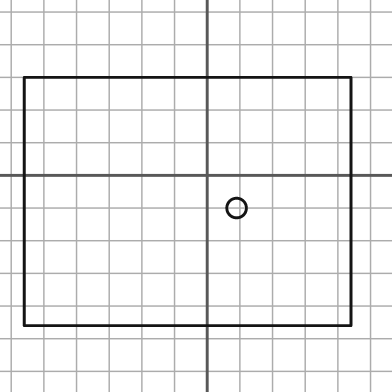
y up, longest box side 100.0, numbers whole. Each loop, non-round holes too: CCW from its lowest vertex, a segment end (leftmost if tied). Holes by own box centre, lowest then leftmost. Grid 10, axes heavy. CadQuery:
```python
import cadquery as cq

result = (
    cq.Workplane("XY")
    .moveTo(-56.0, -46.0)
    .lineTo(44.0, -46.0)
    .lineTo(44.0, 30.0)
    .lineTo(-56.0, 30.0)
    .close()
    .moveTo(9.0, -10.0)
    .circle(3.0)
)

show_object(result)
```